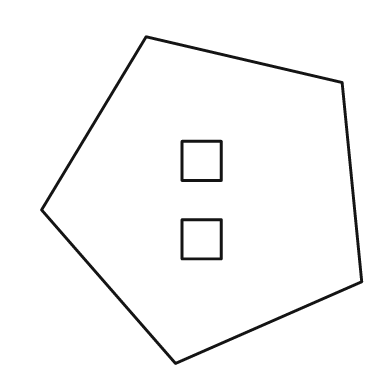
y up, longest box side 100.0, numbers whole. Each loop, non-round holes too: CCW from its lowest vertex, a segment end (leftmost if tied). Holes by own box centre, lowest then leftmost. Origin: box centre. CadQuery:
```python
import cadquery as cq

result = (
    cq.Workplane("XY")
    .moveTo(-8.0, -50.0)
    .lineTo(49.0, -25.0)
    .lineTo(43.0, 36.0)
    .lineTo(-17.0, 50.0)
    .lineTo(-49.0, -3.0)
    .close()
    .moveTo(-6.0, -18.0)
    .lineTo(6.0, -18.0)
    .lineTo(6.0, -6.0)
    .lineTo(-6.0, -6.0)
    .close()
    .moveTo(-6.0, 6.0)
    .lineTo(6.0, 6.0)
    .lineTo(6.0, 18.0)
    .lineTo(-6.0, 18.0)
    .close()
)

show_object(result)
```